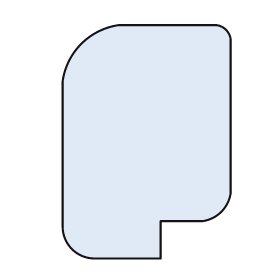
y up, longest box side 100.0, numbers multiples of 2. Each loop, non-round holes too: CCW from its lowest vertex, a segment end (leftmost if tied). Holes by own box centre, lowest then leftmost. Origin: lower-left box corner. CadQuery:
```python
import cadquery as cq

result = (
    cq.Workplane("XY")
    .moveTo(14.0, 0.0)
    .lineTo(42.0, 0.0)
    .lineTo(42.0, 16.0)
    .lineTo(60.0, 16.0)
    .threePointArc((68.0, 20.0), (72.0, 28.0))
    .lineTo(72.0, 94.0)
    .threePointArc((70.0, 98.0), (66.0, 100.0))
    .lineTo(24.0, 100.0)
    .threePointArc((8.0, 92.0), (0.0, 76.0))
    .lineTo(0.0, 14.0)
    .threePointArc((4.0, 4.0), (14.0, 0.0))
    .close()
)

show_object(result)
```